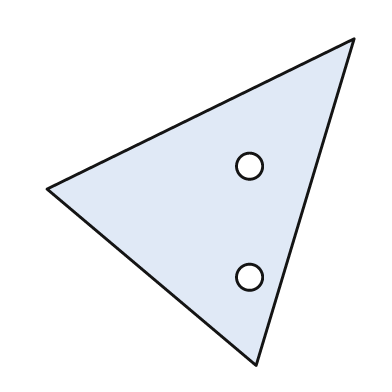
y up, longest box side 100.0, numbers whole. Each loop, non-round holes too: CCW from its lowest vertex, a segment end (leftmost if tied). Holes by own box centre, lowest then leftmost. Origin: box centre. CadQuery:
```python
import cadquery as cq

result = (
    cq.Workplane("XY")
    .moveTo(17.0, -50.0)
    .lineTo(47.0, 50.0)
    .lineTo(-47.0, 4.0)
    .close()
    .moveTo(15.0, -23.0)
    .circle(4.0)
    .moveTo(15.0, 11.0)
    .circle(4.0)
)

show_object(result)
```